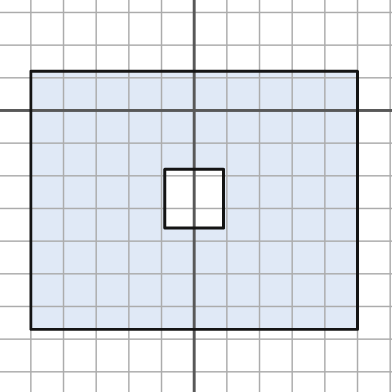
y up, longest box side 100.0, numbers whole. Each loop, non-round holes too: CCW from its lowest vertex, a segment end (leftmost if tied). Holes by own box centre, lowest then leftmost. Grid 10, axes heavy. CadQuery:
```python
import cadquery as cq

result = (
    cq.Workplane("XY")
    .moveTo(-50.0, -67.0)
    .lineTo(50.0, -67.0)
    .lineTo(50.0, 12.0)
    .lineTo(-50.0, 12.0)
    .close()
    .moveTo(-9.0, -36.0)
    .lineTo(9.0, -36.0)
    .lineTo(9.0, -18.0)
    .lineTo(-9.0, -18.0)
    .close()
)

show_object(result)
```